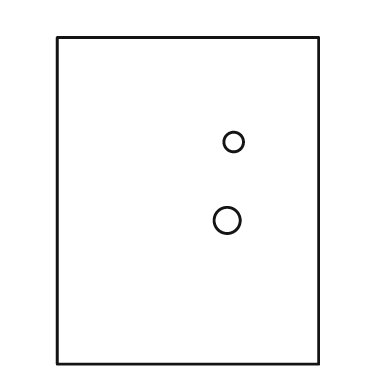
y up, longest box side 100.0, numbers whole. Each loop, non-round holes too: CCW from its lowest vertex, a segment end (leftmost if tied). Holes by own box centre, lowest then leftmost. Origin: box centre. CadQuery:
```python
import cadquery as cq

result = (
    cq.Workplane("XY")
    .moveTo(-40.0, -50.0)
    .lineTo(40.0, -50.0)
    .lineTo(40.0, 50.0)
    .lineTo(-40.0, 50.0)
    .close()
    .moveTo(12.0, -6.0)
    .circle(4.0)
    .moveTo(14.0, 18.0)
    .circle(3.0)
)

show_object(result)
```